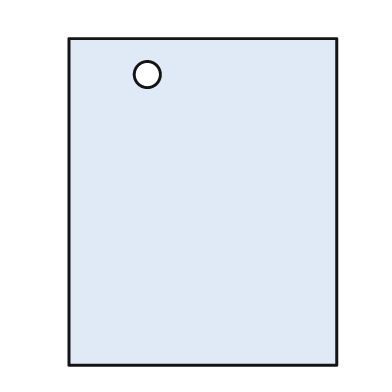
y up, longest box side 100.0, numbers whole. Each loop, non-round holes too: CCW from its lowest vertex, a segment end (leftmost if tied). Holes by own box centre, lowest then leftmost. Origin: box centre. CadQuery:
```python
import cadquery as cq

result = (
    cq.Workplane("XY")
    .moveTo(-41.0, -50.0)
    .lineTo(41.0, -50.0)
    .lineTo(41.0, 50.0)
    .lineTo(-41.0, 50.0)
    .close()
    .moveTo(-17.0, 39.0)
    .circle(4.0)
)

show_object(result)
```